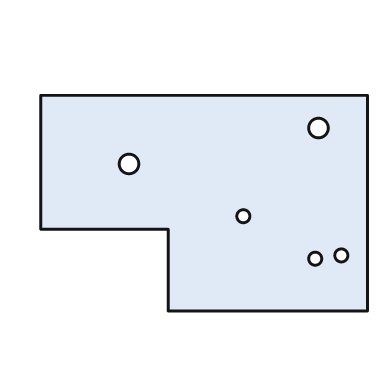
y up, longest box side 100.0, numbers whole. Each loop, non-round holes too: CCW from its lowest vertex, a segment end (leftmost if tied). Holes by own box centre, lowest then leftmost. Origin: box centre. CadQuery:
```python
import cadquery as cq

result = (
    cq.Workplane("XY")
    .moveTo(-11.0, -33.0)
    .lineTo(50.0, -33.0)
    .lineTo(50.0, 33.0)
    .lineTo(-50.0, 33.0)
    .lineTo(-50.0, -8.0)
    .lineTo(-11.0, -8.0)
    .close()
    .moveTo(34.0, -17.0)
    .circle(2.0)
    .moveTo(42.0, -16.0)
    .circle(2.0)
    .moveTo(12.0, -4.0)
    .circle(2.0)
    .moveTo(-23.0, 12.0)
    .circle(3.0)
    .moveTo(35.0, 23.0)
    .circle(3.0)
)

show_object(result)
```